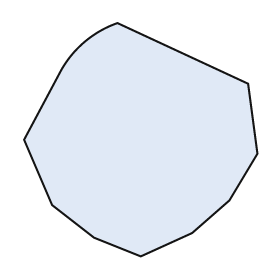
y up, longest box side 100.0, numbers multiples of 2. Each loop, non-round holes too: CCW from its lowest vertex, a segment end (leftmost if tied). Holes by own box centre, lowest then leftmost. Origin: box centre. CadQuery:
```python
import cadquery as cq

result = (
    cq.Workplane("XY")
    .moveTo(0.0, -50.0)
    .lineTo(22.0, -40.0)
    .lineTo(38.0, -26.0)
    .lineTo(50.0, -6.0)
    .lineTo(46.0, 24.0)
    .lineTo(-10.0, 50.0)
    .threePointArc((-24.0, 42.0), (-34.0, 30.0))
    .lineTo(-50.0, 0.0)
    .lineTo(-38.0, -28.0)
    .lineTo(-20.0, -42.0)
    .close()
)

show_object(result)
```